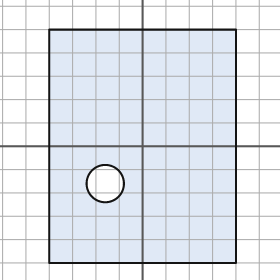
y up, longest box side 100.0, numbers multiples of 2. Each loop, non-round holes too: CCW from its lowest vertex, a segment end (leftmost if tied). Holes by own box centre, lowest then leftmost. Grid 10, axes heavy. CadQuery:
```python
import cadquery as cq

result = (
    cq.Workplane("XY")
    .moveTo(-40.0, -50.0)
    .lineTo(40.0, -50.0)
    .lineTo(40.0, 50.0)
    .lineTo(-40.0, 50.0)
    .close()
    .moveTo(-16.0, -16.0)
    .circle(8.0)
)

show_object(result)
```